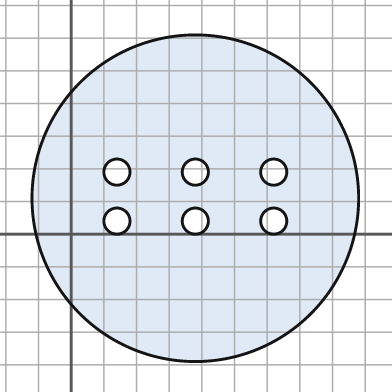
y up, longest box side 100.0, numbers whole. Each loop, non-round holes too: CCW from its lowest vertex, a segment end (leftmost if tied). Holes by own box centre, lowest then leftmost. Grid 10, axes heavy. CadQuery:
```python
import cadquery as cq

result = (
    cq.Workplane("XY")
    .moveTo(38.0, 11.0)
    .circle(50.0)
    .moveTo(14.0, 4.0)
    .circle(4.0)
    .moveTo(38.0, 4.0)
    .circle(4.0)
    .moveTo(62.0, 4.0)
    .circle(4.0)
    .moveTo(14.0, 19.0)
    .circle(4.0)
    .moveTo(38.0, 19.0)
    .circle(4.0)
    .moveTo(62.0, 19.0)
    .circle(4.0)
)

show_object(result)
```